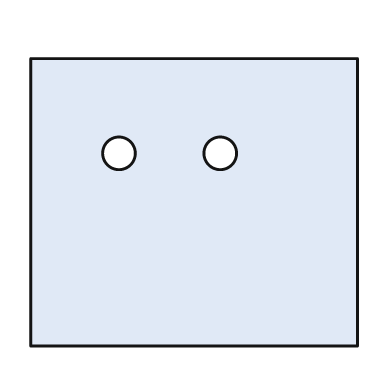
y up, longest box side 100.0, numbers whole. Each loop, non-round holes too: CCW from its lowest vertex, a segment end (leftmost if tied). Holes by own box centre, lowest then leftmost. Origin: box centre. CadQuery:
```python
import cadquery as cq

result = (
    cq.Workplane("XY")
    .moveTo(-50.0, -44.0)
    .lineTo(50.0, -44.0)
    .lineTo(50.0, 44.0)
    .lineTo(-50.0, 44.0)
    .close()
    .moveTo(-23.0, 15.0)
    .circle(5.0)
    .moveTo(8.0, 15.0)
    .circle(5.0)
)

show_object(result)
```